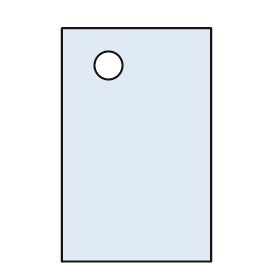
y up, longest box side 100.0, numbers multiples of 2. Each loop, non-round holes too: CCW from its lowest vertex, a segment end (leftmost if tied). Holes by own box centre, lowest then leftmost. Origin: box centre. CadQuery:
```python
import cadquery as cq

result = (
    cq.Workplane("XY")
    .moveTo(-32.0, -50.0)
    .lineTo(32.0, -50.0)
    .lineTo(32.0, 50.0)
    .lineTo(-32.0, 50.0)
    .close()
    .moveTo(-12.0, 34.0)
    .circle(6.0)
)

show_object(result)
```